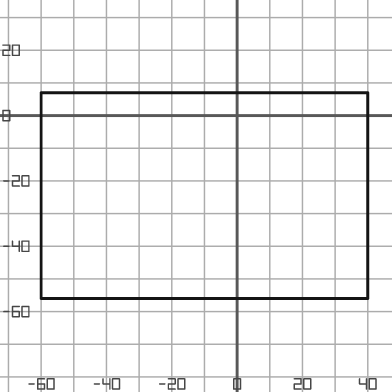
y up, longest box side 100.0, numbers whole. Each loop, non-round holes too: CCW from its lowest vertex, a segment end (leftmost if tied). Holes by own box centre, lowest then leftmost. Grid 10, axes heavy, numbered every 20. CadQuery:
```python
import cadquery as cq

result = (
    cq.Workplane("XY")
    .moveTo(-60.0, -56.0)
    .lineTo(40.0, -56.0)
    .lineTo(40.0, 7.0)
    .lineTo(-60.0, 7.0)
    .close()
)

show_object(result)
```